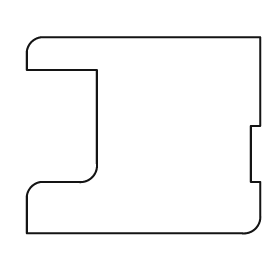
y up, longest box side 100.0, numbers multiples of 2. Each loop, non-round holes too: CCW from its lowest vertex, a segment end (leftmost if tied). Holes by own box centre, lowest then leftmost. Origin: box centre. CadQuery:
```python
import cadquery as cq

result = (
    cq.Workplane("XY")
    .moveTo(-50.0, -42.0)
    .lineTo(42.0, -42.0)
    .threePointArc((48.0, -40.0), (50.0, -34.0))
    .lineTo(50.0, -20.0)
    .lineTo(46.0, -20.0)
    .lineTo(46.0, 4.0)
    .lineTo(50.0, 4.0)
    .lineTo(50.0, 42.0)
    .lineTo(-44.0, 42.0)
    .threePointArc((-48.0, 40.0), (-50.0, 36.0))
    .lineTo(-50.0, 28.0)
    .lineTo(-20.0, 28.0)
    .lineTo(-20.0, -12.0)
    .threePointArc((-22.0, -18.0), (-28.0, -20.0))
    .lineTo(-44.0, -20.0)
    .threePointArc((-48.0, -22.0), (-50.0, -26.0))
    .close()
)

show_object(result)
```